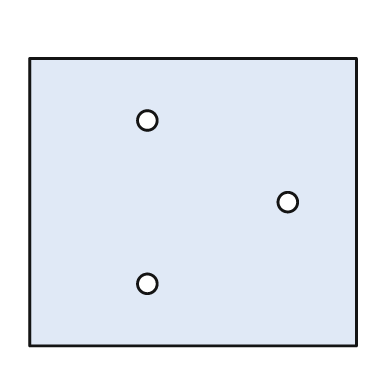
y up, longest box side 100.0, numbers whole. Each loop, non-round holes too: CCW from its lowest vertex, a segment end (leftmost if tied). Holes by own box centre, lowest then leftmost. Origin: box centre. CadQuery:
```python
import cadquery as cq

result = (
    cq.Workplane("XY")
    .moveTo(-50.0, -44.0)
    .lineTo(50.0, -44.0)
    .lineTo(50.0, 44.0)
    .lineTo(-50.0, 44.0)
    .close()
    .moveTo(-14.0, -25.0)
    .circle(3.0)
    .moveTo(29.0, 0.0)
    .circle(3.0)
    .moveTo(-14.0, 25.0)
    .circle(3.0)
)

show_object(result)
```